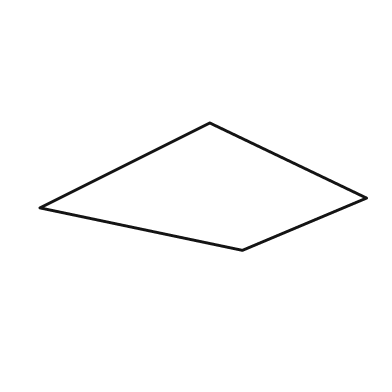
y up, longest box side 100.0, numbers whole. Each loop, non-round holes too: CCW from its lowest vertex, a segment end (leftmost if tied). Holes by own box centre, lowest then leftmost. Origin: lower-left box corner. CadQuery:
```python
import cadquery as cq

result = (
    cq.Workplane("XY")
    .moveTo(62.0, 0.0)
    .lineTo(100.0, 16.0)
    .lineTo(52.0, 39.0)
    .lineTo(0.0, 13.0)
    .close()
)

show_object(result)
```